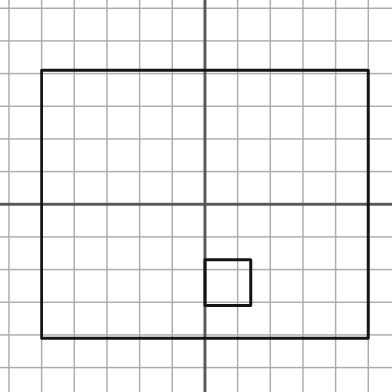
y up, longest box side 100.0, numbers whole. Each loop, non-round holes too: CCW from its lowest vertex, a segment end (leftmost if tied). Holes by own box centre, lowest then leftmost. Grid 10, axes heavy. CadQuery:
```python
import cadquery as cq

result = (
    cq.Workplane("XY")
    .moveTo(-50.0, -41.0)
    .lineTo(50.0, -41.0)
    .lineTo(50.0, 41.0)
    .lineTo(-50.0, 41.0)
    .close()
    .moveTo(0.0, -31.0)
    .lineTo(14.0, -31.0)
    .lineTo(14.0, -17.0)
    .lineTo(0.0, -17.0)
    .close()
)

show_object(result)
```